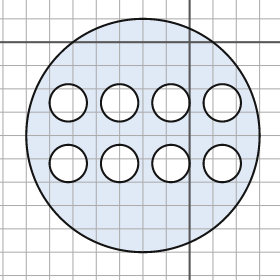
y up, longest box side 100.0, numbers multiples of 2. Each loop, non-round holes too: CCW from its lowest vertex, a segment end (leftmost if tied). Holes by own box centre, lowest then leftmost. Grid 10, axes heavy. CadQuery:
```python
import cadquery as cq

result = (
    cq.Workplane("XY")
    .moveTo(-20.0, -40.0)
    .circle(50.0)
    .moveTo(-52.0, -52.0)
    .circle(8.0)
    .moveTo(-30.0, -52.0)
    .circle(8.0)
    .moveTo(-8.0, -52.0)
    .circle(8.0)
    .moveTo(14.0, -52.0)
    .circle(8.0)
    .moveTo(-52.0, -26.0)
    .circle(8.0)
    .moveTo(-30.0, -26.0)
    .circle(8.0)
    .moveTo(-8.0, -26.0)
    .circle(8.0)
    .moveTo(14.0, -26.0)
    .circle(8.0)
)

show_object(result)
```